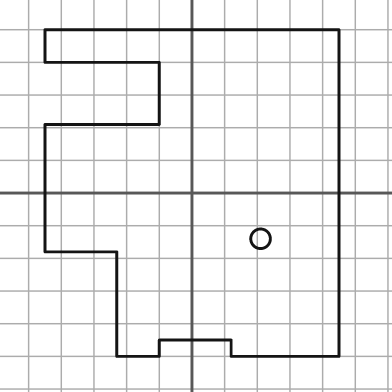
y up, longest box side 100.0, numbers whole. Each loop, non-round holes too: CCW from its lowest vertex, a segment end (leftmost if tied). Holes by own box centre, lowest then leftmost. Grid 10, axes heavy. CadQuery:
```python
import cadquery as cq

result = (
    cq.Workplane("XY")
    .moveTo(-23.0, -50.0)
    .lineTo(-10.0, -50.0)
    .lineTo(-10.0, -45.0)
    .lineTo(12.0, -45.0)
    .lineTo(12.0, -50.0)
    .lineTo(45.0, -50.0)
    .lineTo(45.0, 50.0)
    .lineTo(-45.0, 50.0)
    .lineTo(-45.0, 40.0)
    .lineTo(-10.0, 40.0)
    .lineTo(-10.0, 21.0)
    .lineTo(-45.0, 21.0)
    .lineTo(-45.0, -18.0)
    .lineTo(-23.0, -18.0)
    .close()
    .moveTo(21.0, -14.0)
    .circle(3.0)
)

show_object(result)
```